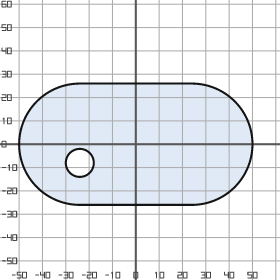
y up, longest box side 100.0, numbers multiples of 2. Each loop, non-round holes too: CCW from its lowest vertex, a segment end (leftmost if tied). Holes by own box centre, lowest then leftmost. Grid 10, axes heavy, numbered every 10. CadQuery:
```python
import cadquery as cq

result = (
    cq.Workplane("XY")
    .moveTo(-24.0, -26.0)
    .lineTo(24.0, -26.0)
    .threePointArc((50.0, 0.0), (24.0, 26.0))
    .lineTo(-24.0, 26.0)
    .threePointArc((-50.0, 0.0), (-24.0, -26.0))
    .close()
    .moveTo(-24.0, -8.0)
    .circle(6.0)
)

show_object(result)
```